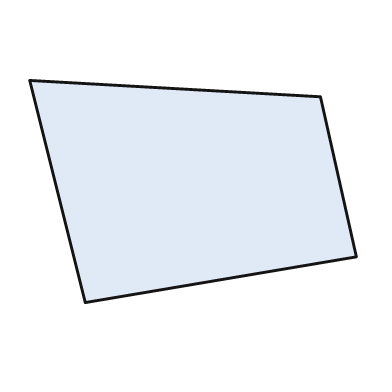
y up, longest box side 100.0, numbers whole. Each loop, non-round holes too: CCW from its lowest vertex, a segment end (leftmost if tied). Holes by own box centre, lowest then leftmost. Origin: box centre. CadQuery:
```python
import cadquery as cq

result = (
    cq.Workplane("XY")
    .moveTo(-33.0, -34.0)
    .lineTo(50.0, -20.0)
    .lineTo(39.0, 29.0)
    .lineTo(-50.0, 34.0)
    .close()
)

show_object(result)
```